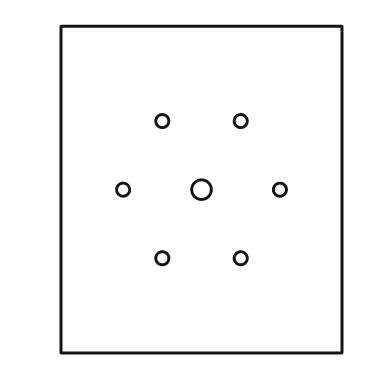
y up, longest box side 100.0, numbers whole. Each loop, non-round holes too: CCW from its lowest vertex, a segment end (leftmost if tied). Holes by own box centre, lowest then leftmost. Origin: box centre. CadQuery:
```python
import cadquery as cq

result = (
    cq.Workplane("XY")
    .moveTo(-43.0, -50.0)
    .lineTo(43.0, -50.0)
    .lineTo(43.0, 50.0)
    .lineTo(-43.0, 50.0)
    .close()
    .moveTo(-12.0, -21.0)
    .circle(2.0)
    .moveTo(12.0, -21.0)
    .circle(2.0)
    .moveTo(-24.0, 0.0)
    .circle(2.0)
    .moveTo(0.0, 0.0)
    .circle(3.0)
    .moveTo(24.0, 0.0)
    .circle(2.0)
    .moveTo(-12.0, 21.0)
    .circle(2.0)
    .moveTo(12.0, 21.0)
    .circle(2.0)
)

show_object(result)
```